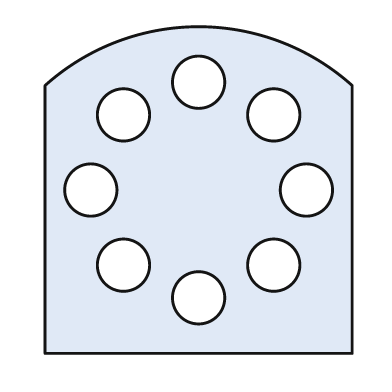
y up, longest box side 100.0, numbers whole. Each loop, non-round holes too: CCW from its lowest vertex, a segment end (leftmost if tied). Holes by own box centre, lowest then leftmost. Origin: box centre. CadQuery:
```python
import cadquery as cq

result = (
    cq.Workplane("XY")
    .moveTo(-47.0, -50.0)
    .lineTo(47.0, -50.0)
    .lineTo(47.0, 32.0)
    .threePointArc((0.0, 50.0), (-47.0, 32.0))
    .close()
    .moveTo(0.0, -33.0)
    .circle(8.0)
    .moveTo(-23.0, -23.0)
    .circle(8.0)
    .moveTo(23.0, -23.0)
    .circle(8.0)
    .moveTo(-33.0, 0.0)
    .circle(8.0)
    .moveTo(33.0, 0.0)
    .circle(8.0)
    .moveTo(-23.0, 23.0)
    .circle(8.0)
    .moveTo(23.0, 23.0)
    .circle(8.0)
    .moveTo(0.0, 33.0)
    .circle(8.0)
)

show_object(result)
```